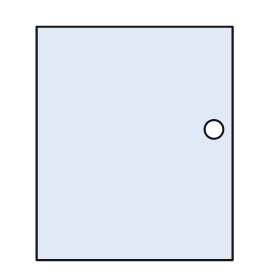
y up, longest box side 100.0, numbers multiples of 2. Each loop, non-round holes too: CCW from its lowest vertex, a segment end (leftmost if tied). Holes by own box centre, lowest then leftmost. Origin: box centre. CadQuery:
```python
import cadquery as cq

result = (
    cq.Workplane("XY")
    .moveTo(-42.0, -50.0)
    .lineTo(42.0, -50.0)
    .lineTo(42.0, 50.0)
    .lineTo(-42.0, 50.0)
    .close()
    .moveTo(34.0, 6.0)
    .circle(4.0)
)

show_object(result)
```